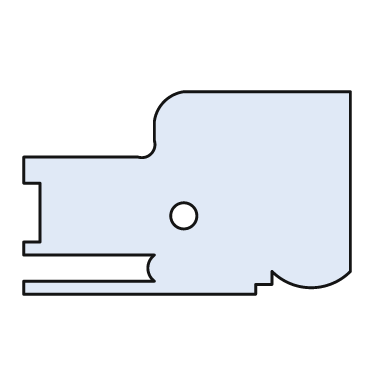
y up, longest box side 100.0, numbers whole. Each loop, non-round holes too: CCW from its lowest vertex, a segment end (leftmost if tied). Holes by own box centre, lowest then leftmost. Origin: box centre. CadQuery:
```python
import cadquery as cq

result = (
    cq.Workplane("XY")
    .moveTo(-50.0, -31.0)
    .lineTo(21.0, -31.0)
    .lineTo(21.0, -28.0)
    .lineTo(26.0, -28.0)
    .lineTo(26.0, -24.0)
    .threePointArc((38.0, -29.0), (50.0, -24.0))
    .lineTo(50.0, 31.0)
    .lineTo(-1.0, 31.0)
    .threePointArc((-7.0, 28.0), (-10.0, 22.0))
    .lineTo(-10.0, 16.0)
    .threePointArc((-11.0, 12.0), (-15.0, 11.0))
    .lineTo(-50.0, 11.0)
    .lineTo(-50.0, 3.0)
    .lineTo(-45.0, 3.0)
    .lineTo(-45.0, -15.0)
    .lineTo(-50.0, -15.0)
    .lineTo(-50.0, -19.0)
    .lineTo(-10.0, -19.0)
    .threePointArc((-12.0, -23.0), (-10.0, -27.0))
    .lineTo(-50.0, -27.0)
    .close()
    .moveTo(-1.0, -7.0)
    .circle(4.0)
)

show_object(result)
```